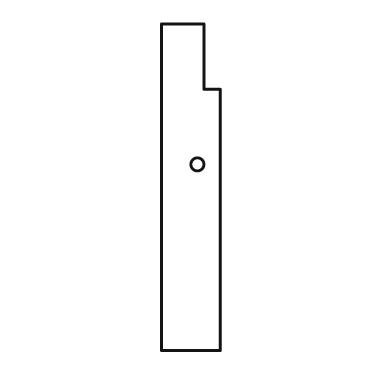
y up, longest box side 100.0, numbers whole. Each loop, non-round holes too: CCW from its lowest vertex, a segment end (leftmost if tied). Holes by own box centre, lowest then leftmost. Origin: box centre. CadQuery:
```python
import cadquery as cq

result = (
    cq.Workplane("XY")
    .moveTo(-9.0, -50.0)
    .lineTo(9.0, -50.0)
    .lineTo(9.0, 30.0)
    .lineTo(4.0, 30.0)
    .lineTo(4.0, 50.0)
    .lineTo(-9.0, 50.0)
    .close()
    .moveTo(2.0, 7.0)
    .circle(2.0)
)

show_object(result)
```